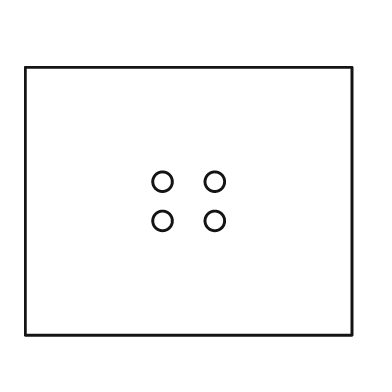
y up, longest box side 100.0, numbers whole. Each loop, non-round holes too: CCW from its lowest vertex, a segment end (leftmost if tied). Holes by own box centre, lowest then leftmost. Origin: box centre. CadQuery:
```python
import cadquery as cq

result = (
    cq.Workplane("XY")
    .moveTo(-50.0, -41.0)
    .lineTo(50.0, -41.0)
    .lineTo(50.0, 41.0)
    .lineTo(-50.0, 41.0)
    .close()
    .moveTo(-8.0, -6.0)
    .circle(3.0)
    .moveTo(8.0, -6.0)
    .circle(3.0)
    .moveTo(-8.0, 6.0)
    .circle(3.0)
    .moveTo(8.0, 6.0)
    .circle(3.0)
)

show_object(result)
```